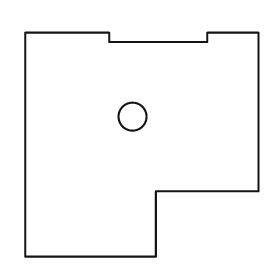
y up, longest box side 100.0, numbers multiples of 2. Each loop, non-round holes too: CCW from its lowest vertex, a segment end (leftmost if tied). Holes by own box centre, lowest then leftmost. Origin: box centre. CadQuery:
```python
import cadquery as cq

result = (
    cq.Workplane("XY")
    .moveTo(-50.0, -48.0)
    .lineTo(6.0, -48.0)
    .lineTo(6.0, -20.0)
    .lineTo(50.0, -20.0)
    .lineTo(50.0, 48.0)
    .lineTo(28.0, 48.0)
    .lineTo(28.0, 44.0)
    .lineTo(-14.0, 44.0)
    .lineTo(-14.0, 48.0)
    .lineTo(-50.0, 48.0)
    .close()
    .moveTo(-4.0, 12.0)
    .circle(6.0)
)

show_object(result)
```